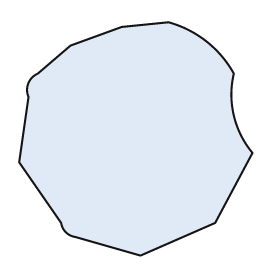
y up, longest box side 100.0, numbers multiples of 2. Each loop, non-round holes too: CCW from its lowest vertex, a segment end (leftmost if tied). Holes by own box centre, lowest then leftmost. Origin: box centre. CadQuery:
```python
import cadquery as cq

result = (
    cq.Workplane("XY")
    .moveTo(2.0, -50.0)
    .lineTo(34.0, -36.0)
    .lineTo(50.0, -6.0)
    .threePointArc((42.0, 10.0), (42.0, 28.0))
    .threePointArc((30.0, 42.0), (14.0, 50.0))
    .lineTo(-6.0, 48.0)
    .lineTo(-28.0, 40.0)
    .lineTo(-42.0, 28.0)
    .threePointArc((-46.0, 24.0), (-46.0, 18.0))
    .lineTo(-50.0, -10.0)
    .lineTo(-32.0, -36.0)
    .threePointArc((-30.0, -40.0), (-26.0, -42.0))
    .close()
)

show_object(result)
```